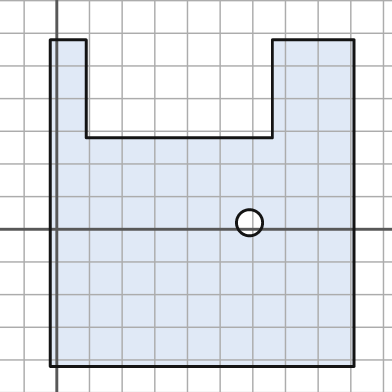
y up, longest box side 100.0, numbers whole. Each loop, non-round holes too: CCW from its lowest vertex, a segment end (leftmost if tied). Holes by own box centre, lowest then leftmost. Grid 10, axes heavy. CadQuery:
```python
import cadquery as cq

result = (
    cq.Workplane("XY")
    .moveTo(-2.0, -42.0)
    .lineTo(91.0, -42.0)
    .lineTo(91.0, 58.0)
    .lineTo(66.0, 58.0)
    .lineTo(66.0, 28.0)
    .lineTo(9.0, 28.0)
    .lineTo(9.0, 58.0)
    .lineTo(-2.0, 58.0)
    .close()
    .moveTo(59.0, 2.0)
    .circle(4.0)
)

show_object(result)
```